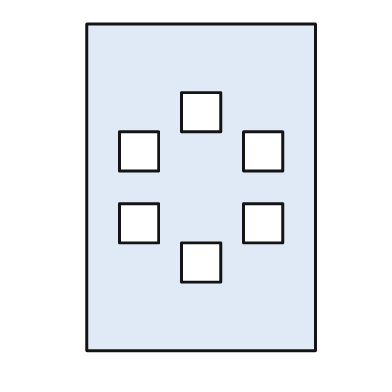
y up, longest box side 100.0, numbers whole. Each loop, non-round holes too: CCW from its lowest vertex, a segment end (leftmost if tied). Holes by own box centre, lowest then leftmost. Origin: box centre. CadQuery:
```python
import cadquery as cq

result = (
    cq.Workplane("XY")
    .moveTo(-35.0, -50.0)
    .lineTo(35.0, -50.0)
    .lineTo(35.0, 50.0)
    .lineTo(-35.0, 50.0)
    .close()
    .moveTo(-6.0, -29.0)
    .lineTo(6.0, -29.0)
    .lineTo(6.0, -17.0)
    .lineTo(-6.0, -17.0)
    .close()
    .moveTo(-25.0, -17.0)
    .lineTo(-13.0, -17.0)
    .lineTo(-13.0, -5.0)
    .lineTo(-25.0, -5.0)
    .close()
    .moveTo(13.0, -17.0)
    .lineTo(25.0, -17.0)
    .lineTo(25.0, -5.0)
    .lineTo(13.0, -5.0)
    .close()
    .moveTo(-25.0, 5.0)
    .lineTo(-13.0, 5.0)
    .lineTo(-13.0, 17.0)
    .lineTo(-25.0, 17.0)
    .close()
    .moveTo(13.0, 5.0)
    .lineTo(25.0, 5.0)
    .lineTo(25.0, 17.0)
    .lineTo(13.0, 17.0)
    .close()
    .moveTo(-6.0, 17.0)
    .lineTo(6.0, 17.0)
    .lineTo(6.0, 29.0)
    .lineTo(-6.0, 29.0)
    .close()
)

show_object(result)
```